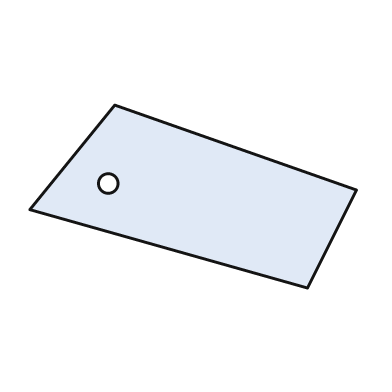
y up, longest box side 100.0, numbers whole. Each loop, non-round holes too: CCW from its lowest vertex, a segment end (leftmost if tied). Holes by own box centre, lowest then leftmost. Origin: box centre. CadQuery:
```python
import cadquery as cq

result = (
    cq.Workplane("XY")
    .moveTo(35.0, -28.0)
    .lineTo(50.0, 2.0)
    .lineTo(-24.0, 28.0)
    .lineTo(-50.0, -4.0)
    .close()
    .moveTo(-26.0, 4.0)
    .circle(3.0)
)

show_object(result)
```